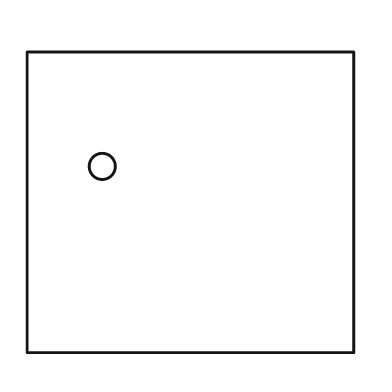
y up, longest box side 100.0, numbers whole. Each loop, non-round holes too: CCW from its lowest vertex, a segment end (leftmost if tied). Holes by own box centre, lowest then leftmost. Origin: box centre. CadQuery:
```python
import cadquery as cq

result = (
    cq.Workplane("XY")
    .moveTo(-50.0, -46.0)
    .lineTo(50.0, -46.0)
    .lineTo(50.0, 46.0)
    .lineTo(-50.0, 46.0)
    .close()
    .moveTo(-27.0, 11.0)
    .circle(4.0)
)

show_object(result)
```